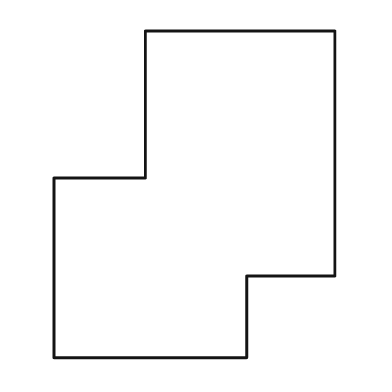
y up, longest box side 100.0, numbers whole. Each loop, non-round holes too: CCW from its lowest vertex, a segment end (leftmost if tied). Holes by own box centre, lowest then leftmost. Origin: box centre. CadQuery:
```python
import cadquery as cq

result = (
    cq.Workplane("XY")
    .moveTo(-43.0, -50.0)
    .lineTo(16.0, -50.0)
    .lineTo(16.0, -25.0)
    .lineTo(43.0, -25.0)
    .lineTo(43.0, 50.0)
    .lineTo(-15.0, 50.0)
    .lineTo(-15.0, 5.0)
    .lineTo(-43.0, 5.0)
    .close()
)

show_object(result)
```